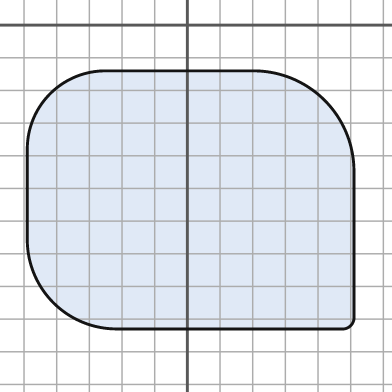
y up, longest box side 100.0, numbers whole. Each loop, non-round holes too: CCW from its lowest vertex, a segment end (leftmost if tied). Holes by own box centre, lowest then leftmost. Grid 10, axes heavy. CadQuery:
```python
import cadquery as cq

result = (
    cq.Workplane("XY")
    .moveTo(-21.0, -93.0)
    .lineTo(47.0, -93.0)
    .threePointArc((50.0, -92.0), (51.0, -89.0))
    .lineTo(51.0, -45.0)
    .threePointArc((42.0, -23.0), (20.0, -14.0))
    .lineTo(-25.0, -14.0)
    .threePointArc((-42.0, -21.0), (-49.0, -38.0))
    .lineTo(-49.0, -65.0)
    .threePointArc((-41.0, -85.0), (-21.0, -93.0))
    .close()
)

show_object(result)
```